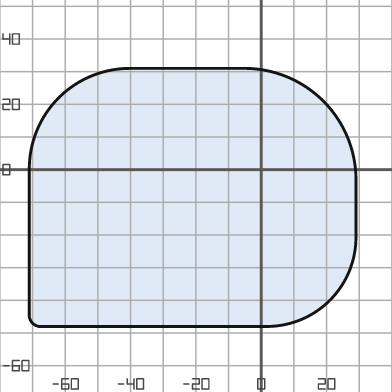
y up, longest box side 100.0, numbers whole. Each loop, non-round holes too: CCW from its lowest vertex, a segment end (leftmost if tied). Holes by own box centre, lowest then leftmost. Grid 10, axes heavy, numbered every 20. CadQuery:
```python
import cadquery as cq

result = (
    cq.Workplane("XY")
    .moveTo(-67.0, -48.0)
    .lineTo(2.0, -48.0)
    .threePointArc((21.0, -40.0), (29.0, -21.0))
    .lineTo(29.0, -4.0)
    .threePointArc((19.0, 21.0), (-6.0, 31.0))
    .lineTo(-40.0, 31.0)
    .threePointArc((-62.0, 22.0), (-71.0, 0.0))
    .lineTo(-71.0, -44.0)
    .threePointArc((-70.0, -47.0), (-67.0, -48.0))
    .close()
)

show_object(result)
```